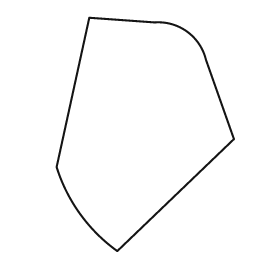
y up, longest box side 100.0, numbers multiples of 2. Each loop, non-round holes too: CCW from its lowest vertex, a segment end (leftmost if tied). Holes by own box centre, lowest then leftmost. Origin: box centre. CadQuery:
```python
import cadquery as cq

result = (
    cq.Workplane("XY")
    .moveTo(-12.0, -50.0)
    .lineTo(38.0, -2.0)
    .lineTo(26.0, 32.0)
    .threePointArc((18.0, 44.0), (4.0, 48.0))
    .lineTo(-24.0, 50.0)
    .lineTo(-38.0, -14.0)
    .threePointArc((-28.0, -34.0), (-12.0, -50.0))
    .close()
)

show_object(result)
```